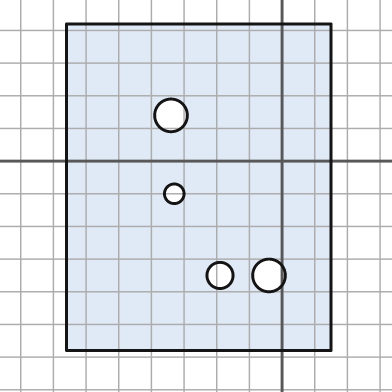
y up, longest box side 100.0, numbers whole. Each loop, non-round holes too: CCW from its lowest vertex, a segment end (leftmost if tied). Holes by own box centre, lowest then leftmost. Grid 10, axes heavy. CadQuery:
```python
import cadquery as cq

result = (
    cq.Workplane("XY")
    .moveTo(-66.0, -58.0)
    .lineTo(15.0, -58.0)
    .lineTo(15.0, 42.0)
    .lineTo(-66.0, 42.0)
    .close()
    .moveTo(-19.0, -35.0)
    .circle(4.0)
    .moveTo(-4.0, -35.0)
    .circle(5.0)
    .moveTo(-33.0, -10.0)
    .circle(3.0)
    .moveTo(-34.0, 14.0)
    .circle(5.0)
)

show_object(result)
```